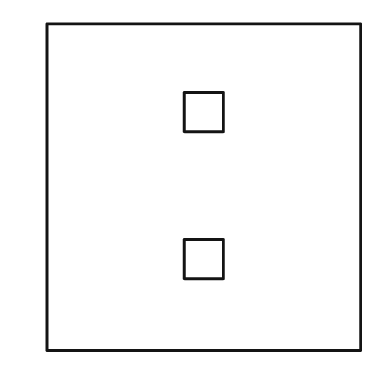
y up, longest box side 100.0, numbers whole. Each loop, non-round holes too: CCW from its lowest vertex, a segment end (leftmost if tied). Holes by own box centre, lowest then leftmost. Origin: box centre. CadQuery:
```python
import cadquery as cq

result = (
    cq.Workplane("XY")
    .moveTo(-48.0, -50.0)
    .lineTo(48.0, -50.0)
    .lineTo(48.0, 50.0)
    .lineTo(-48.0, 50.0)
    .close()
    .moveTo(-6.0, -28.0)
    .lineTo(6.0, -28.0)
    .lineTo(6.0, -16.0)
    .lineTo(-6.0, -16.0)
    .close()
    .moveTo(-6.0, 17.0)
    .lineTo(6.0, 17.0)
    .lineTo(6.0, 29.0)
    .lineTo(-6.0, 29.0)
    .close()
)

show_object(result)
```